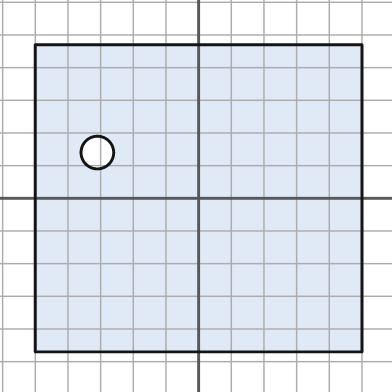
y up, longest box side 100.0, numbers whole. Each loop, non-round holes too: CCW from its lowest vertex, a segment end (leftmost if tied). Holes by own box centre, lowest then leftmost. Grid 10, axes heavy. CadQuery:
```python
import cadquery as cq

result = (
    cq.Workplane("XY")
    .moveTo(-50.0, -47.0)
    .lineTo(50.0, -47.0)
    .lineTo(50.0, 47.0)
    .lineTo(-50.0, 47.0)
    .close()
    .moveTo(-31.0, 14.0)
    .circle(5.0)
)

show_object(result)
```